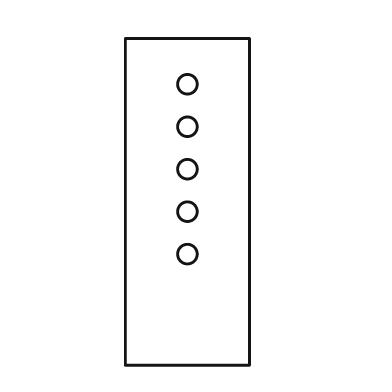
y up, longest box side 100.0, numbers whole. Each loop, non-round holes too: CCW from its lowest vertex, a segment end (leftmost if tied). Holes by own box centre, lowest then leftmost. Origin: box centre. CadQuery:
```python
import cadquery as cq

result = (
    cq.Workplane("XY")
    .moveTo(-19.0, -50.0)
    .lineTo(19.0, -50.0)
    .lineTo(19.0, 50.0)
    .lineTo(-19.0, 50.0)
    .close()
    .moveTo(0.0, -16.0)
    .circle(3.0)
    .moveTo(0.0, -3.0)
    .circle(3.0)
    .moveTo(0.0, 10.0)
    .circle(3.0)
    .moveTo(0.0, 23.0)
    .circle(3.0)
    .moveTo(0.0, 36.0)
    .circle(3.0)
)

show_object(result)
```